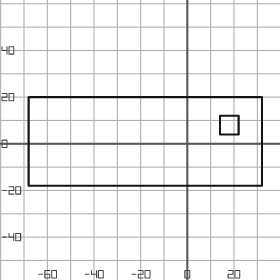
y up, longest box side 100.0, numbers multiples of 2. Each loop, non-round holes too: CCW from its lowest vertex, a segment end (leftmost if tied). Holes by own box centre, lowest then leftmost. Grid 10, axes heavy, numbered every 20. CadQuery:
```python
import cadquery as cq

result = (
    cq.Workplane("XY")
    .moveTo(-68.0, -18.0)
    .lineTo(32.0, -18.0)
    .lineTo(32.0, 20.0)
    .lineTo(-68.0, 20.0)
    .close()
    .moveTo(14.0, 4.0)
    .lineTo(22.0, 4.0)
    .lineTo(22.0, 12.0)
    .lineTo(14.0, 12.0)
    .close()
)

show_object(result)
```